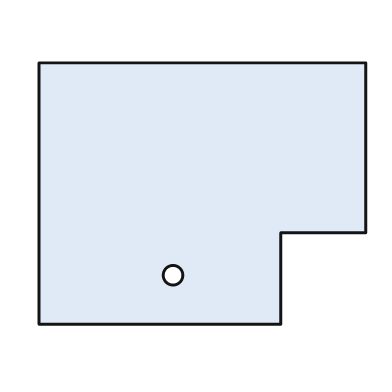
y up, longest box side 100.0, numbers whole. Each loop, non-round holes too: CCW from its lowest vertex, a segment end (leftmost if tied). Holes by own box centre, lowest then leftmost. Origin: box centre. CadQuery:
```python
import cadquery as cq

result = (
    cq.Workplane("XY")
    .moveTo(-50.0, -40.0)
    .lineTo(24.0, -40.0)
    .lineTo(24.0, -12.0)
    .lineTo(50.0, -12.0)
    .lineTo(50.0, 40.0)
    .lineTo(-50.0, 40.0)
    .close()
    .moveTo(-9.0, -25.0)
    .circle(3.0)
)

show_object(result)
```